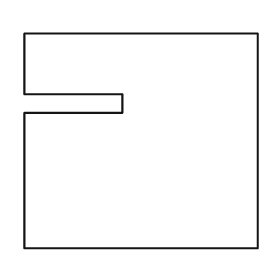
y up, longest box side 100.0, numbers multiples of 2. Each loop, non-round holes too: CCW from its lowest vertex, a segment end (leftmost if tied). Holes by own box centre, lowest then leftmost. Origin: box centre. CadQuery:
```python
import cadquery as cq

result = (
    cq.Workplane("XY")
    .moveTo(-50.0, -46.0)
    .lineTo(50.0, -46.0)
    .lineTo(50.0, 46.0)
    .lineTo(-50.0, 46.0)
    .lineTo(-50.0, 20.0)
    .lineTo(-8.0, 20.0)
    .lineTo(-8.0, 12.0)
    .lineTo(-50.0, 12.0)
    .close()
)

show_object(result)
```